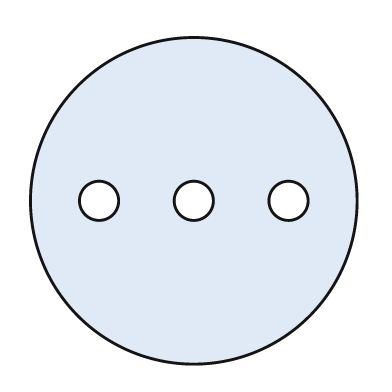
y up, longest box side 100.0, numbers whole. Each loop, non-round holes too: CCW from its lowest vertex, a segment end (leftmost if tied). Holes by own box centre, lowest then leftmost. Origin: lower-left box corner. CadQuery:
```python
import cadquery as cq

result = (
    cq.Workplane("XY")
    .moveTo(50.0, 50.0)
    .circle(50.0)
    .moveTo(21.0, 50.0)
    .circle(6.0)
    .moveTo(50.0, 50.0)
    .circle(6.0)
    .moveTo(79.0, 50.0)
    .circle(6.0)
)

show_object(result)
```